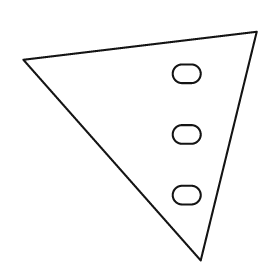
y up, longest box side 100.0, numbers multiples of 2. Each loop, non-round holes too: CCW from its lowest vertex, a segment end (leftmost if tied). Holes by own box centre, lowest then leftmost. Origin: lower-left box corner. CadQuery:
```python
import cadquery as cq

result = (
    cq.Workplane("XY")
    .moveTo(76.0, 0.0)
    .lineTo(100.0, 98.0)
    .lineTo(0.0, 86.0)
    .close()
    .moveTo(68.0, 24.0)
    .lineTo(72.0, 24.0)
    .threePointArc((76.0, 28.0), (72.0, 32.0))
    .lineTo(68.0, 32.0)
    .threePointArc((64.0, 28.0), (68.0, 24.0))
    .close()
    .moveTo(68.0, 50.0)
    .lineTo(72.0, 50.0)
    .threePointArc((76.0, 54.0), (72.0, 58.0))
    .lineTo(68.0, 58.0)
    .threePointArc((64.0, 54.0), (68.0, 50.0))
    .close()
    .moveTo(68.0, 76.0)
    .lineTo(72.0, 76.0)
    .threePointArc((76.0, 80.0), (72.0, 84.0))
    .lineTo(68.0, 84.0)
    .threePointArc((64.0, 80.0), (68.0, 76.0))
    .close()
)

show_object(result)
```